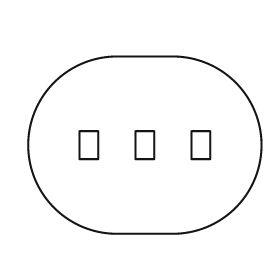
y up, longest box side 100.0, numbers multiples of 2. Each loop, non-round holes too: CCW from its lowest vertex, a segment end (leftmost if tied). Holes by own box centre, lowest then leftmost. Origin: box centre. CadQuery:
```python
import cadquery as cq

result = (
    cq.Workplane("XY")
    .moveTo(-12.0, -38.0)
    .lineTo(12.0, -38.0)
    .threePointArc((50.0, 0.0), (12.0, 38.0))
    .lineTo(-12.0, 38.0)
    .threePointArc((-50.0, 0.0), (-12.0, -38.0))
    .close()
    .moveTo(-28.0, -6.0)
    .lineTo(-20.0, -6.0)
    .lineTo(-20.0, 6.0)
    .lineTo(-28.0, 6.0)
    .close()
    .moveTo(-4.0, -6.0)
    .lineTo(4.0, -6.0)
    .lineTo(4.0, 6.0)
    .lineTo(-4.0, 6.0)
    .close()
    .moveTo(20.0, -6.0)
    .lineTo(28.0, -6.0)
    .lineTo(28.0, 6.0)
    .lineTo(20.0, 6.0)
    .close()
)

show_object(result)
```